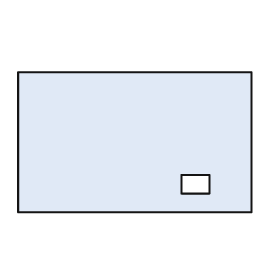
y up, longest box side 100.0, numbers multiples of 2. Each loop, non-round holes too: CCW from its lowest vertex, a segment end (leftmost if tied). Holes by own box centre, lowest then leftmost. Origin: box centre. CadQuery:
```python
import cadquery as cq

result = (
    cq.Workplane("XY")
    .moveTo(-50.0, -30.0)
    .lineTo(50.0, -30.0)
    .lineTo(50.0, 30.0)
    .lineTo(-50.0, 30.0)
    .close()
    .moveTo(20.0, -22.0)
    .lineTo(32.0, -22.0)
    .lineTo(32.0, -14.0)
    .lineTo(20.0, -14.0)
    .close()
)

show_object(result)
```